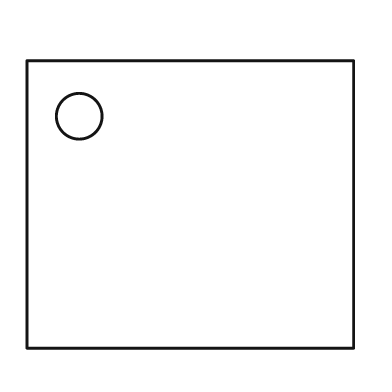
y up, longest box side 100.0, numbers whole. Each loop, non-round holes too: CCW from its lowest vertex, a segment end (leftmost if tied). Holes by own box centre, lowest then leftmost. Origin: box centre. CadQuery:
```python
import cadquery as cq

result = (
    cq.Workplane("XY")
    .moveTo(-50.0, -44.0)
    .lineTo(50.0, -44.0)
    .lineTo(50.0, 44.0)
    .lineTo(-50.0, 44.0)
    .close()
    .moveTo(-34.0, 27.0)
    .circle(7.0)
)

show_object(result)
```